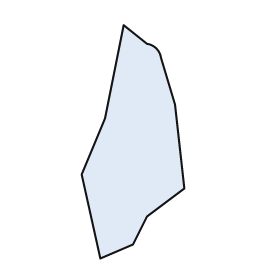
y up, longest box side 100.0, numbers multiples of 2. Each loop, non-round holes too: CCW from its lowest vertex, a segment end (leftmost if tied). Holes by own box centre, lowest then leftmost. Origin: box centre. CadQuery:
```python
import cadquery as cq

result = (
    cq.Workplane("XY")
    .moveTo(-14.0, -50.0)
    .lineTo(0.0, -44.0)
    .lineTo(6.0, -32.0)
    .lineTo(22.0, -20.0)
    .lineTo(18.0, 16.0)
    .lineTo(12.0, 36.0)
    .threePointArc((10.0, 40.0), (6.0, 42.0))
    .lineTo(-4.0, 50.0)
    .lineTo(-12.0, 10.0)
    .lineTo(-22.0, -14.0)
    .close()
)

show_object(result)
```